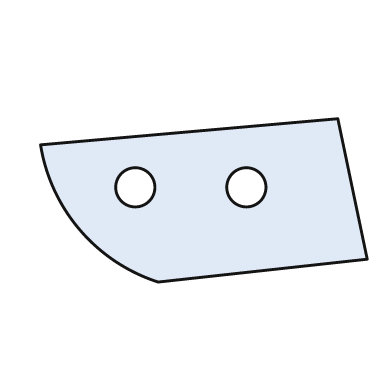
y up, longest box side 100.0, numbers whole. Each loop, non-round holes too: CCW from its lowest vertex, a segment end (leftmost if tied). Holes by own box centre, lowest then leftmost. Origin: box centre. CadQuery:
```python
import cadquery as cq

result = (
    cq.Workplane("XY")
    .moveTo(-14.0, -25.0)
    .lineTo(50.0, -18.0)
    .lineTo(41.0, 25.0)
    .lineTo(-50.0, 17.0)
    .threePointArc((-38.0, -9.0), (-14.0, -25.0))
    .close()
    .moveTo(-21.0, 4.0)
    .circle(6.0)
    .moveTo(13.0, 4.0)
    .circle(6.0)
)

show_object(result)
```